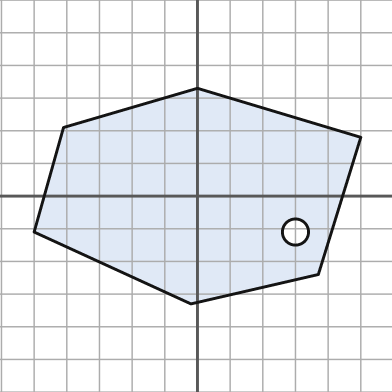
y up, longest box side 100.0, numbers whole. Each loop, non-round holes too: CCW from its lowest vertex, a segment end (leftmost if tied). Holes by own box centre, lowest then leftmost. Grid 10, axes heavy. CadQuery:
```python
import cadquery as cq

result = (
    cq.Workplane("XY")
    .moveTo(-2.0, -33.0)
    .lineTo(37.0, -24.0)
    .lineTo(50.0, 18.0)
    .lineTo(0.0, 33.0)
    .lineTo(-41.0, 21.0)
    .lineTo(-50.0, -11.0)
    .close()
    .moveTo(30.0, -11.0)
    .circle(4.0)
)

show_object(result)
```